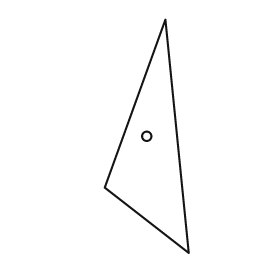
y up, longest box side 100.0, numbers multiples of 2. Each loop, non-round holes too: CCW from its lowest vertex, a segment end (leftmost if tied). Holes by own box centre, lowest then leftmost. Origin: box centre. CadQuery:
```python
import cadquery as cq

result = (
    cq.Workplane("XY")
    .moveTo(18.0, -50.0)
    .lineTo(8.0, 50.0)
    .lineTo(-18.0, -22.0)
    .close()
    .moveTo(0.0, 0.0)
    .circle(2.0)
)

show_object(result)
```